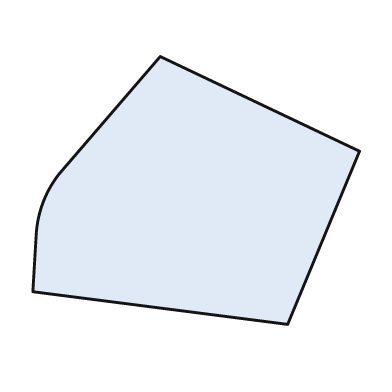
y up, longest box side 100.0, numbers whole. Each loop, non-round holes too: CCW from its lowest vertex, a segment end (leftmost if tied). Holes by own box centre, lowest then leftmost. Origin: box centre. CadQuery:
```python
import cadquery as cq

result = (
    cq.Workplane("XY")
    .moveTo(28.0, -41.0)
    .lineTo(50.0, 12.0)
    .lineTo(-11.0, 41.0)
    .lineTo(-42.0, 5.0)
    .threePointArc((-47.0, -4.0), (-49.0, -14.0))
    .lineTo(-50.0, -31.0)
    .close()
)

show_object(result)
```